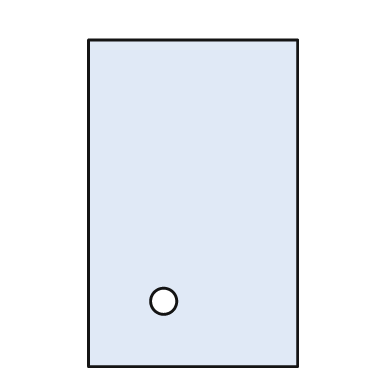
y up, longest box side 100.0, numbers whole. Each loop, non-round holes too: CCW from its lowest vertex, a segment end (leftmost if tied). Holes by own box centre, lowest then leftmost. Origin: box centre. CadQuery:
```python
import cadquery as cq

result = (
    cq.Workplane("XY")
    .moveTo(-32.0, -50.0)
    .lineTo(32.0, -50.0)
    .lineTo(32.0, 50.0)
    .lineTo(-32.0, 50.0)
    .close()
    .moveTo(-9.0, -30.0)
    .circle(4.0)
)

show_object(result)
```